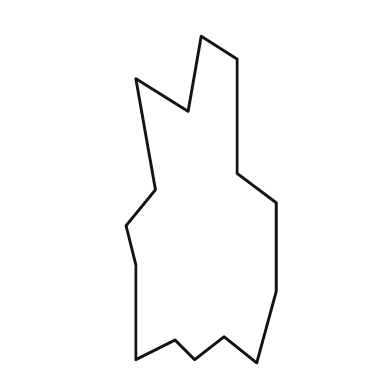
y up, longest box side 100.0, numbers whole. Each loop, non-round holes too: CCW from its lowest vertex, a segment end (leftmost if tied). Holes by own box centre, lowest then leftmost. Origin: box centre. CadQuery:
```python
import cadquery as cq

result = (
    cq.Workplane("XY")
    .moveTo(17.0, -50.0)
    .lineTo(23.0, -28.0)
    .lineTo(23.0, -1.0)
    .lineTo(11.0, 8.0)
    .lineTo(11.0, 43.0)
    .lineTo(0.0, 50.0)
    .lineTo(-4.0, 27.0)
    .lineTo(-20.0, 37.0)
    .lineTo(-14.0, 3.0)
    .lineTo(-23.0, -8.0)
    .lineTo(-20.0, -20.0)
    .lineTo(-20.0, -49.0)
    .lineTo(-8.0, -43.0)
    .lineTo(-2.0, -49.0)
    .lineTo(7.0, -42.0)
    .close()
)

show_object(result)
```